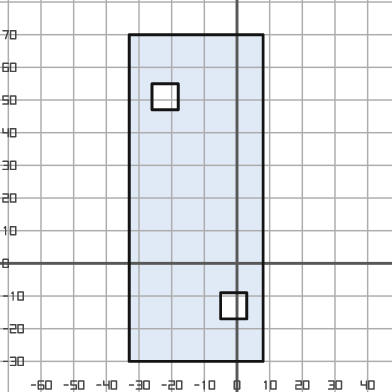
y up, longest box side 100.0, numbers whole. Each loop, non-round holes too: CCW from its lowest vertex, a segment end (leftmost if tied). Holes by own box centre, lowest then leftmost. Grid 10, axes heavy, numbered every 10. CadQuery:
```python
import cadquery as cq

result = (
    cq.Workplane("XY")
    .moveTo(-33.0, -30.0)
    .lineTo(8.0, -30.0)
    .lineTo(8.0, 70.0)
    .lineTo(-33.0, 70.0)
    .close()
    .moveTo(-5.0, -17.0)
    .lineTo(3.0, -17.0)
    .lineTo(3.0, -9.0)
    .lineTo(-5.0, -9.0)
    .close()
    .moveTo(-26.0, 47.0)
    .lineTo(-18.0, 47.0)
    .lineTo(-18.0, 55.0)
    .lineTo(-26.0, 55.0)
    .close()
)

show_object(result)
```